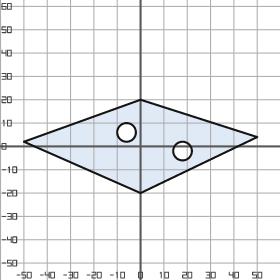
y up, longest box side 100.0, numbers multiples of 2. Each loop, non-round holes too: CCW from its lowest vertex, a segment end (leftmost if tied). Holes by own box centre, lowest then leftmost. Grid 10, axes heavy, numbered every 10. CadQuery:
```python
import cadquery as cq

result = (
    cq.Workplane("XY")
    .moveTo(0.0, -20.0)
    .lineTo(50.0, 4.0)
    .lineTo(0.0, 20.0)
    .lineTo(-50.0, 2.0)
    .close()
    .moveTo(18.0, -2.0)
    .circle(4.0)
    .moveTo(-6.0, 6.0)
    .circle(4.0)
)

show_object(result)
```